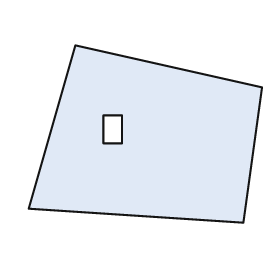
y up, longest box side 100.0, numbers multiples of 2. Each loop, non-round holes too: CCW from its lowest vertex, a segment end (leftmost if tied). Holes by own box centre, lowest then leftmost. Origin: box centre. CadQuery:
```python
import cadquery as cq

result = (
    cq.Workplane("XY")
    .moveTo(42.0, -38.0)
    .lineTo(50.0, 20.0)
    .lineTo(-30.0, 38.0)
    .lineTo(-50.0, -32.0)
    .close()
    .moveTo(-18.0, -4.0)
    .lineTo(-10.0, -4.0)
    .lineTo(-10.0, 8.0)
    .lineTo(-18.0, 8.0)
    .close()
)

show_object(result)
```